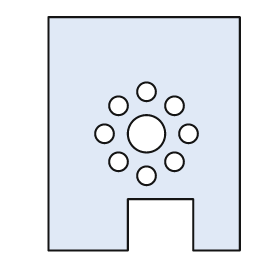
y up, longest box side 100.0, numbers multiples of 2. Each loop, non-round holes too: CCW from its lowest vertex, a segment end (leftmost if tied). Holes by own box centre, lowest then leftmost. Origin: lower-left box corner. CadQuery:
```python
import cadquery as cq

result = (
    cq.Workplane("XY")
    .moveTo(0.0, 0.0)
    .lineTo(34.0, 0.0)
    .lineTo(34.0, 22.0)
    .lineTo(62.0, 22.0)
    .lineTo(62.0, 0.0)
    .lineTo(82.0, 0.0)
    .lineTo(82.0, 100.0)
    .lineTo(0.0, 100.0)
    .close()
    .moveTo(42.0, 32.0)
    .circle(4.0)
    .moveTo(30.0, 38.0)
    .circle(4.0)
    .moveTo(54.0, 38.0)
    .circle(4.0)
    .moveTo(24.0, 50.0)
    .circle(4.0)
    .moveTo(42.0, 50.0)
    .circle(8.0)
    .moveTo(60.0, 50.0)
    .circle(4.0)
    .moveTo(30.0, 62.0)
    .circle(4.0)
    .moveTo(54.0, 62.0)
    .circle(4.0)
    .moveTo(42.0, 68.0)
    .circle(4.0)
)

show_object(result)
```